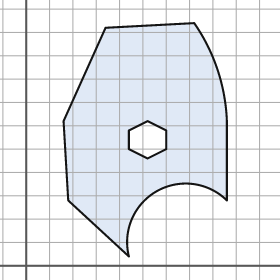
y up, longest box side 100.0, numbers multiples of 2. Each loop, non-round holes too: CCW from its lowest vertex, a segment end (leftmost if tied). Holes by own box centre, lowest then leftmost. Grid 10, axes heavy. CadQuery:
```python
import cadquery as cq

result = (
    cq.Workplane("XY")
    .moveTo(44.0, 4.0)
    .threePointArc((56.0, 32.0), (86.0, 28.0))
    .lineTo(86.0, 62.0)
    .threePointArc((82.0, 84.0), (72.0, 104.0))
    .lineTo(34.0, 102.0)
    .lineTo(16.0, 62.0)
    .lineTo(18.0, 28.0)
    .close()
    .moveTo(52.0, 46.0)
    .lineTo(60.0, 50.0)
    .lineTo(60.0, 58.0)
    .lineTo(52.0, 62.0)
    .lineTo(44.0, 58.0)
    .lineTo(44.0, 50.0)
    .close()
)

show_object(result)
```